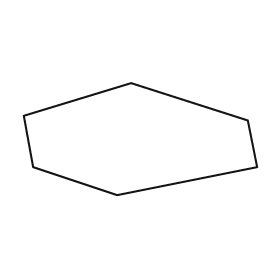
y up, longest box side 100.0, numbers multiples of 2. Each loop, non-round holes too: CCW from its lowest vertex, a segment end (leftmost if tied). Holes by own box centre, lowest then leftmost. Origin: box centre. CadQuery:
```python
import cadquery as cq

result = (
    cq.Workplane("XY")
    .moveTo(-10.0, -24.0)
    .lineTo(50.0, -12.0)
    .lineTo(46.0, 8.0)
    .lineTo(-4.0, 24.0)
    .lineTo(-50.0, 10.0)
    .lineTo(-46.0, -12.0)
    .close()
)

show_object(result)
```